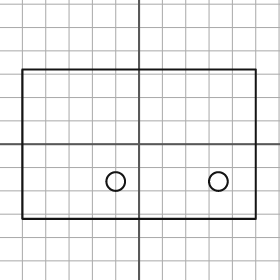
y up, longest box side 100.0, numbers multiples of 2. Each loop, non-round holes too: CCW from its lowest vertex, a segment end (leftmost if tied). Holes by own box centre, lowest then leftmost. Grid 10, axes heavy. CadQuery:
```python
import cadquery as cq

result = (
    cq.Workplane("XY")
    .moveTo(-50.0, -32.0)
    .lineTo(50.0, -32.0)
    .lineTo(50.0, 32.0)
    .lineTo(-50.0, 32.0)
    .close()
    .moveTo(-10.0, -16.0)
    .circle(4.0)
    .moveTo(34.0, -16.0)
    .circle(4.0)
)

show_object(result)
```